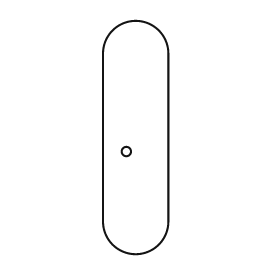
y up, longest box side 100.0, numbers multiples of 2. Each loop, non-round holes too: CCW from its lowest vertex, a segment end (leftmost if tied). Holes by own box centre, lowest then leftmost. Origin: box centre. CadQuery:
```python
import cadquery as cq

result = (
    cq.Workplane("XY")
    .moveTo(-14.0, -36.0)
    .threePointArc((0.0, -50.0), (14.0, -36.0))
    .lineTo(14.0, 36.0)
    .threePointArc((0.0, 50.0), (-14.0, 36.0))
    .close()
    .moveTo(-4.0, -6.0)
    .circle(2.0)
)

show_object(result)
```